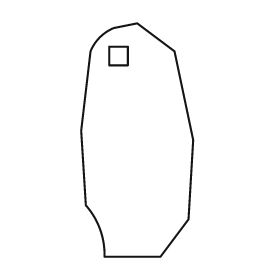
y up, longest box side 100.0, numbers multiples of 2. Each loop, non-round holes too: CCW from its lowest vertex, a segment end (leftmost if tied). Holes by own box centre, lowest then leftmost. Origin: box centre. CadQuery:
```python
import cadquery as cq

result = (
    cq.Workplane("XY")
    .moveTo(-14.0, -50.0)
    .lineTo(10.0, -50.0)
    .lineTo(22.0, -34.0)
    .lineTo(24.0, 0.0)
    .lineTo(16.0, 38.0)
    .lineTo(0.0, 50.0)
    .lineTo(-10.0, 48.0)
    .threePointArc((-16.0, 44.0), (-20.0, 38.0))
    .lineTo(-24.0, 4.0)
    .lineTo(-22.0, -28.0)
    .threePointArc((-16.0, -38.0), (-14.0, -50.0))
    .close()
    .moveTo(-12.0, 32.0)
    .lineTo(-4.0, 32.0)
    .lineTo(-4.0, 40.0)
    .lineTo(-12.0, 40.0)
    .close()
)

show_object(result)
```